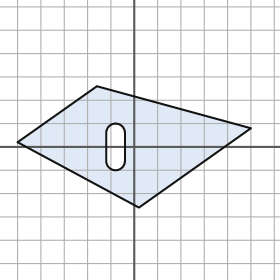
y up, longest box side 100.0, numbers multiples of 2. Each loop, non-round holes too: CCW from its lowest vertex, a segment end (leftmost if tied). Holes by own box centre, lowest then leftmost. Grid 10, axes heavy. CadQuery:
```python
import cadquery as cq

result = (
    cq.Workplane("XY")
    .moveTo(2.0, -26.0)
    .lineTo(50.0, 8.0)
    .lineTo(-16.0, 26.0)
    .lineTo(-50.0, 2.0)
    .close()
    .moveTo(-12.0, -6.0)
    .threePointArc((-8.0, -10.0), (-4.0, -6.0))
    .lineTo(-4.0, 6.0)
    .threePointArc((-8.0, 10.0), (-12.0, 6.0))
    .close()
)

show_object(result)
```